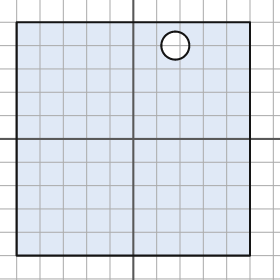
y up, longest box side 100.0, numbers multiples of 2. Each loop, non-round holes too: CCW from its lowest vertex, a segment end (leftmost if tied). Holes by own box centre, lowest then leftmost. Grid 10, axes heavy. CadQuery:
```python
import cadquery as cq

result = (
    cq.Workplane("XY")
    .moveTo(-50.0, -50.0)
    .lineTo(50.0, -50.0)
    .lineTo(50.0, 50.0)
    .lineTo(-50.0, 50.0)
    .close()
    .moveTo(18.0, 40.0)
    .circle(6.0)
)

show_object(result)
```